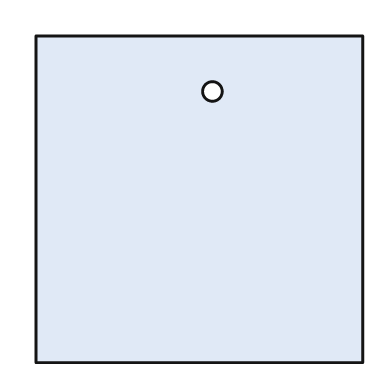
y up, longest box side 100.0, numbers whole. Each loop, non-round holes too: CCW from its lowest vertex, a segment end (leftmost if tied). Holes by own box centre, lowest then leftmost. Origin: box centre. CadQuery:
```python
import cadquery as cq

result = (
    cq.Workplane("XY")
    .moveTo(-50.0, -50.0)
    .lineTo(50.0, -50.0)
    .lineTo(50.0, 50.0)
    .lineTo(-50.0, 50.0)
    .close()
    .moveTo(4.0, 33.0)
    .circle(3.0)
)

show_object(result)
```